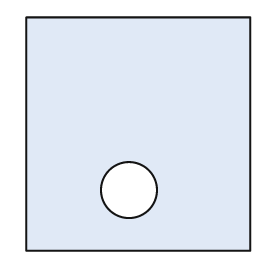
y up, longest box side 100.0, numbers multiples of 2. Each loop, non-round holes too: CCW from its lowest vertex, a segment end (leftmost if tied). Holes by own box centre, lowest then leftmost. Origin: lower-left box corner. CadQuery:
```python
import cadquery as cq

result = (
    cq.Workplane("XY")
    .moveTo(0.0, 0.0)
    .lineTo(96.0, 0.0)
    .lineTo(96.0, 100.0)
    .lineTo(0.0, 100.0)
    .close()
    .moveTo(44.0, 26.0)
    .circle(12.0)
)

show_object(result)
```